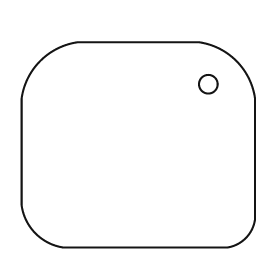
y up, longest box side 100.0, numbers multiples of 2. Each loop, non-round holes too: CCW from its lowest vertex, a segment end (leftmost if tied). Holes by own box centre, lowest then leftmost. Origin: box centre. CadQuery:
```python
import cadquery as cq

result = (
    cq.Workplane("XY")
    .moveTo(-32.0, -44.0)
    .lineTo(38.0, -44.0)
    .threePointArc((46.0, -40.0), (50.0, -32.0))
    .lineTo(50.0, 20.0)
    .threePointArc((42.0, 36.0), (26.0, 44.0))
    .lineTo(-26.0, 44.0)
    .threePointArc((-42.0, 36.0), (-50.0, 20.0))
    .lineTo(-50.0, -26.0)
    .threePointArc((-44.0, -38.0), (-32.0, -44.0))
    .close()
    .moveTo(30.0, 26.0)
    .circle(4.0)
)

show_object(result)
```